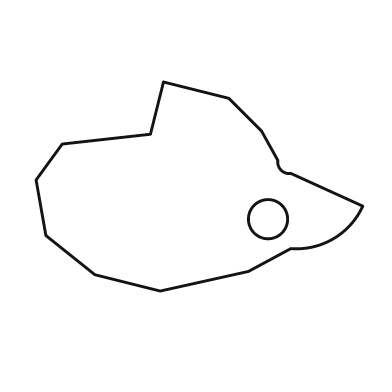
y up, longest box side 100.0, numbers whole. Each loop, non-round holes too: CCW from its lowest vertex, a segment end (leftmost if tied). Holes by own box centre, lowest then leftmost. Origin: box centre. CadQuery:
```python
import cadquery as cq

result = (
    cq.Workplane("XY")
    .moveTo(-12.0, -32.0)
    .lineTo(15.0, -26.0)
    .lineTo(28.0, -19.0)
    .threePointArc((41.0, -16.0), (50.0, -6.0))
    .lineTo(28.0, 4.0)
    .threePointArc((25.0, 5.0), (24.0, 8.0))
    .lineTo(19.0, 17.0)
    .lineTo(9.0, 27.0)
    .lineTo(-11.0, 32.0)
    .lineTo(-15.0, 16.0)
    .lineTo(-42.0, 13.0)
    .lineTo(-50.0, 2.0)
    .lineTo(-47.0, -15.0)
    .lineTo(-32.0, -27.0)
    .close()
    .moveTo(21.0, -10.0)
    .circle(6.0)
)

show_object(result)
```